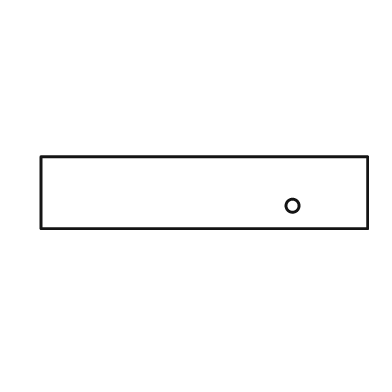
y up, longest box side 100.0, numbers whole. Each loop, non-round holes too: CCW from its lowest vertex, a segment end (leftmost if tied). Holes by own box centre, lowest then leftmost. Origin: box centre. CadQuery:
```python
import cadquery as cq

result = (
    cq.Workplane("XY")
    .moveTo(-50.0, -11.0)
    .lineTo(50.0, -11.0)
    .lineTo(50.0, 11.0)
    .lineTo(-50.0, 11.0)
    .close()
    .moveTo(27.0, -4.0)
    .circle(2.0)
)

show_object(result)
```